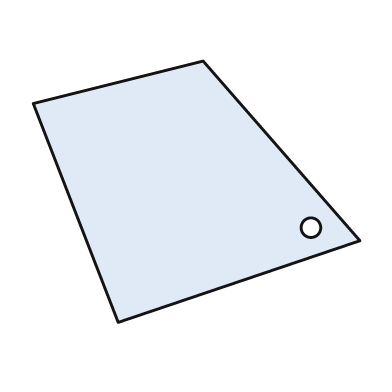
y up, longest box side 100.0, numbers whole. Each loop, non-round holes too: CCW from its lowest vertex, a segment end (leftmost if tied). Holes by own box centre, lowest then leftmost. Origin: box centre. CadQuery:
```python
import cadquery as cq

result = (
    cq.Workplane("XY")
    .moveTo(-24.0, -40.0)
    .lineTo(50.0, -15.0)
    .lineTo(2.0, 40.0)
    .lineTo(-50.0, 27.0)
    .close()
    .moveTo(35.0, -11.0)
    .circle(3.0)
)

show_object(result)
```